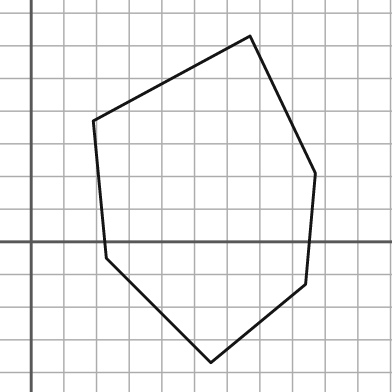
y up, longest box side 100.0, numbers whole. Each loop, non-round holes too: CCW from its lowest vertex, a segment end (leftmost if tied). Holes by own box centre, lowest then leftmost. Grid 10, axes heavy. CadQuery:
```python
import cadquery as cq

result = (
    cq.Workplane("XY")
    .moveTo(55.0, -37.0)
    .lineTo(84.0, -13.0)
    .lineTo(87.0, 21.0)
    .lineTo(67.0, 63.0)
    .lineTo(19.0, 37.0)
    .lineTo(23.0, -5.0)
    .close()
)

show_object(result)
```